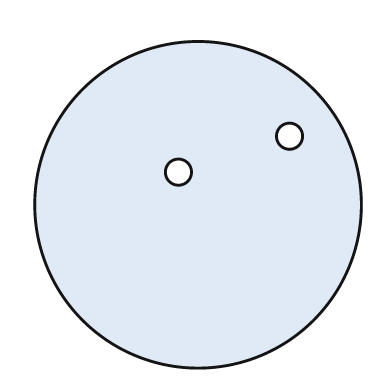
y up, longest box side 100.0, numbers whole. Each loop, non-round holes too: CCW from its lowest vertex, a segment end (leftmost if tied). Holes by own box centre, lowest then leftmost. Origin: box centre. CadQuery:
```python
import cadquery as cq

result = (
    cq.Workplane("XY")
    .moveTo(0.0, 0.0)
    .circle(50.0)
    .moveTo(-6.0, 10.0)
    .circle(4.0)
    .moveTo(28.0, 21.0)
    .circle(4.0)
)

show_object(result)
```